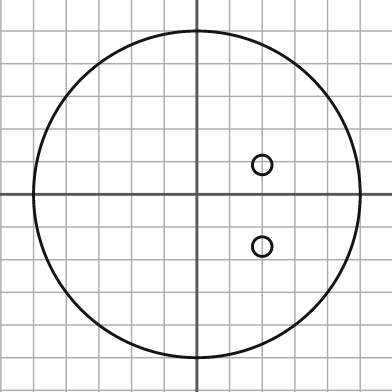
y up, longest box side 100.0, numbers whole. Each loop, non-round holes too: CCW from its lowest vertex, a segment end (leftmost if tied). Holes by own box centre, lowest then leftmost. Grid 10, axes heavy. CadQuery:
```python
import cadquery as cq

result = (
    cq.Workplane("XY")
    .moveTo(0.0, 0.0)
    .circle(50.0)
    .moveTo(20.0, -16.0)
    .circle(3.0)
    .moveTo(20.0, 9.0)
    .circle(3.0)
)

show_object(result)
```